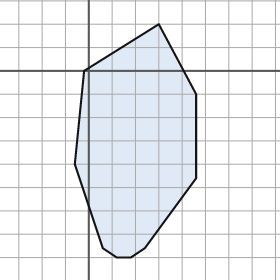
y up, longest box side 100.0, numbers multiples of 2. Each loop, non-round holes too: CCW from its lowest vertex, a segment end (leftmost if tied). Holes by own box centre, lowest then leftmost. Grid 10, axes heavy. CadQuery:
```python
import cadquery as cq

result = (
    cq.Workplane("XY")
    .moveTo(12.0, -80.0)
    .lineTo(18.0, -80.0)
    .lineTo(24.0, -76.0)
    .lineTo(46.0, -46.0)
    .lineTo(46.0, -10.0)
    .lineTo(30.0, 20.0)
    .lineTo(-2.0, 0.0)
    .lineTo(-6.0, -40.0)
    .lineTo(6.0, -76.0)
    .close()
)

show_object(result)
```